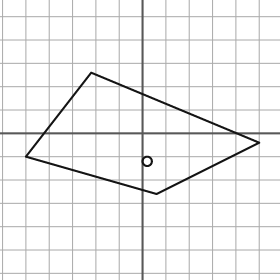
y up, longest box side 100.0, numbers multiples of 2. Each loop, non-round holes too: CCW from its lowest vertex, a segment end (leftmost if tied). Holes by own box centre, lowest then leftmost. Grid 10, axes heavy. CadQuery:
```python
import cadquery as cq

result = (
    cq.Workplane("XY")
    .moveTo(6.0, -26.0)
    .lineTo(50.0, -4.0)
    .lineTo(-22.0, 26.0)
    .lineTo(-50.0, -10.0)
    .close()
    .moveTo(2.0, -12.0)
    .circle(2.0)
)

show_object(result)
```